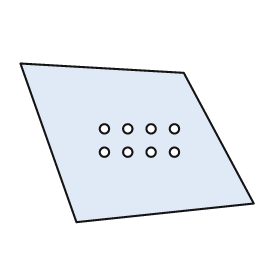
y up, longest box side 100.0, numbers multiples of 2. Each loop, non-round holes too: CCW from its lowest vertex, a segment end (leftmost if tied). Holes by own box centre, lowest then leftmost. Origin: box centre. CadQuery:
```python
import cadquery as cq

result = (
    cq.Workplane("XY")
    .moveTo(-26.0, -34.0)
    .lineTo(50.0, -26.0)
    .lineTo(20.0, 30.0)
    .lineTo(-50.0, 34.0)
    .close()
    .moveTo(-14.0, -4.0)
    .circle(2.0)
    .moveTo(-4.0, -4.0)
    .circle(2.0)
    .moveTo(6.0, -4.0)
    .circle(2.0)
    .moveTo(16.0, -4.0)
    .circle(2.0)
    .moveTo(-14.0, 6.0)
    .circle(2.0)
    .moveTo(-4.0, 6.0)
    .circle(2.0)
    .moveTo(6.0, 6.0)
    .circle(2.0)
    .moveTo(16.0, 6.0)
    .circle(2.0)
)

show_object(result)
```